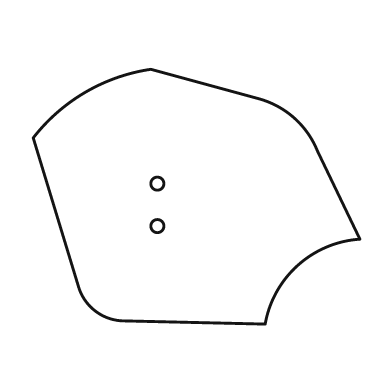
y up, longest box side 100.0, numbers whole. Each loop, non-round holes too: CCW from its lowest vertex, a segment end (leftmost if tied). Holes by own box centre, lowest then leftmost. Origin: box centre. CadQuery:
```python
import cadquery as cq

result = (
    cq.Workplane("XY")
    .moveTo(21.0, -39.0)
    .threePointArc((31.0, -21.0), (50.0, -13.0))
    .lineTo(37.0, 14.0)
    .threePointArc((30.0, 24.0), (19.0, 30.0))
    .lineTo(-14.0, 39.0)
    .threePointArc((-34.0, 32.0), (-50.0, 18.0))
    .lineTo(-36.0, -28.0)
    .threePointArc((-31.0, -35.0), (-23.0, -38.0))
    .close()
    .moveTo(-12.0, -9.0)
    .circle(2.0)
    .moveTo(-12.0, 4.0)
    .circle(2.0)
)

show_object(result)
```